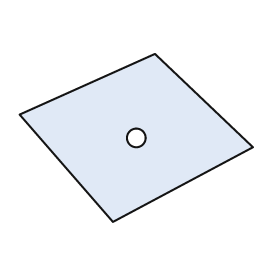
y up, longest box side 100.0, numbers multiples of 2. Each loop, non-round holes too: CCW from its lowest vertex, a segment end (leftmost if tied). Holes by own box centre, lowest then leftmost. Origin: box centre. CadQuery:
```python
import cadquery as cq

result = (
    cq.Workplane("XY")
    .moveTo(-10.0, -36.0)
    .lineTo(50.0, -4.0)
    .lineTo(8.0, 36.0)
    .lineTo(-50.0, 10.0)
    .close()
    .moveTo(0.0, 0.0)
    .circle(4.0)
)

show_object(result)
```